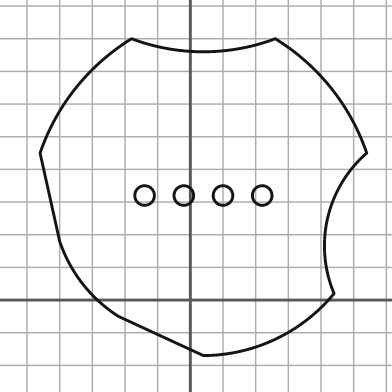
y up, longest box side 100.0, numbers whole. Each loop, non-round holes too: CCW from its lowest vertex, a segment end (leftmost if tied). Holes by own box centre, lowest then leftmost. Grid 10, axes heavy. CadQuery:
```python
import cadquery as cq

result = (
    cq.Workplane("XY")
    .moveTo(4.0, -17.0)
    .threePointArc((26.0, -12.0), (44.0, 2.0))
    .threePointArc((42.0, 25.0), (54.0, 45.0))
    .threePointArc((43.0, 65.0), (26.0, 80.0))
    .threePointArc((4.0, 76.0), (-18.0, 80.0))
    .threePointArc((-35.0, 65.0), (-46.0, 45.0))
    .lineTo(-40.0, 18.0)
    .threePointArc((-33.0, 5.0), (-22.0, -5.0))
    .close()
    .moveTo(-14.0, 32.0)
    .circle(3.0)
    .moveTo(-2.0, 32.0)
    .circle(3.0)
    .moveTo(10.0, 32.0)
    .circle(3.0)
    .moveTo(22.0, 32.0)
    .circle(3.0)
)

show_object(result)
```